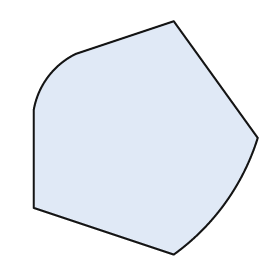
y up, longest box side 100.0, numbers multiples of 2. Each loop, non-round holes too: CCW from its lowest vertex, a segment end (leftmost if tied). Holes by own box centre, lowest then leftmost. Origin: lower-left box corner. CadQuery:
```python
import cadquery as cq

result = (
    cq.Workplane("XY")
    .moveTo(60.0, 0.0)
    .threePointArc((82.0, 22.0), (96.0, 50.0))
    .lineTo(60.0, 100.0)
    .lineTo(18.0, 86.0)
    .threePointArc((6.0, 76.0), (0.0, 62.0))
    .lineTo(0.0, 20.0)
    .close()
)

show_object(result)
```